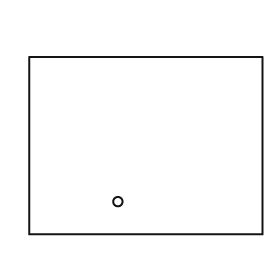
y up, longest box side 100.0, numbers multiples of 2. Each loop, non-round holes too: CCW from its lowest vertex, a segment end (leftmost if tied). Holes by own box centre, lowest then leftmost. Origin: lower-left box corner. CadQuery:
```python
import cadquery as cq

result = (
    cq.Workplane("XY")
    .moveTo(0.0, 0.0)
    .lineTo(100.0, 0.0)
    .lineTo(100.0, 76.0)
    .lineTo(0.0, 76.0)
    .close()
    .moveTo(38.0, 14.0)
    .circle(2.0)
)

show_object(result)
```